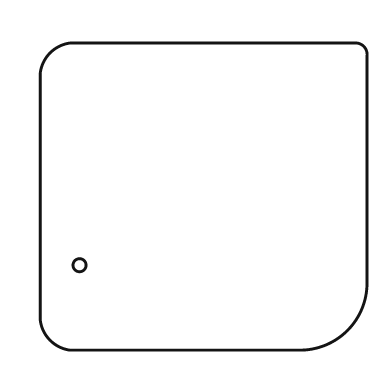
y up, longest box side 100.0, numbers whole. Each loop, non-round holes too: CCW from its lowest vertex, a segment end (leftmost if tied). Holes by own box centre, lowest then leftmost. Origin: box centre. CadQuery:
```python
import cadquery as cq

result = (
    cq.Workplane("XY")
    .moveTo(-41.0, -47.0)
    .lineTo(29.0, -47.0)
    .threePointArc((44.0, -41.0), (50.0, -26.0))
    .lineTo(50.0, 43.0)
    .threePointArc((49.0, 46.0), (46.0, 47.0))
    .lineTo(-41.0, 47.0)
    .threePointArc((-47.0, 44.0), (-50.0, 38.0))
    .lineTo(-50.0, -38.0)
    .threePointArc((-47.0, -44.0), (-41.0, -47.0))
    .close()
    .moveTo(-38.0, -21.0)
    .circle(2.0)
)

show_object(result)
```